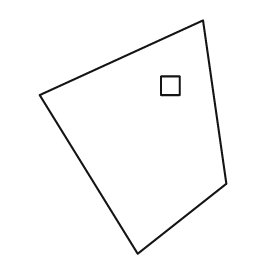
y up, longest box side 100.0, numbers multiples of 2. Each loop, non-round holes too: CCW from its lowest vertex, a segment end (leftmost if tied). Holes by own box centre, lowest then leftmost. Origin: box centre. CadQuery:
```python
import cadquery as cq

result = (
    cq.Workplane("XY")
    .moveTo(2.0, -50.0)
    .lineTo(40.0, -20.0)
    .lineTo(30.0, 50.0)
    .lineTo(-40.0, 18.0)
    .close()
    .moveTo(12.0, 18.0)
    .lineTo(20.0, 18.0)
    .lineTo(20.0, 26.0)
    .lineTo(12.0, 26.0)
    .close()
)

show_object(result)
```